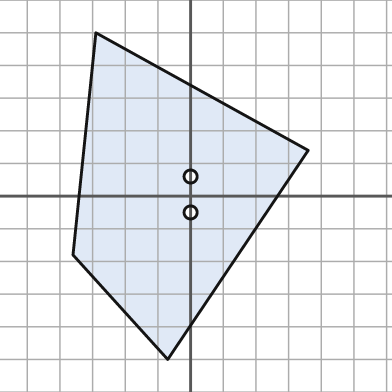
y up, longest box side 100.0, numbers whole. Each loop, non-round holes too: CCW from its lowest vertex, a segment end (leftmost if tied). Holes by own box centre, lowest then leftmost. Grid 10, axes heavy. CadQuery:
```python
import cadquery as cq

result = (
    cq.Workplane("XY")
    .moveTo(-7.0, -50.0)
    .lineTo(36.0, 14.0)
    .lineTo(-29.0, 50.0)
    .lineTo(-36.0, -18.0)
    .close()
    .moveTo(0.0, -5.0)
    .circle(2.0)
    .moveTo(0.0, 6.0)
    .circle(2.0)
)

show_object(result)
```